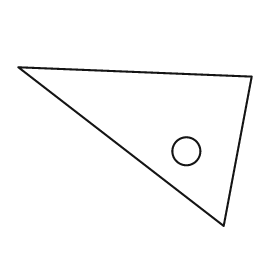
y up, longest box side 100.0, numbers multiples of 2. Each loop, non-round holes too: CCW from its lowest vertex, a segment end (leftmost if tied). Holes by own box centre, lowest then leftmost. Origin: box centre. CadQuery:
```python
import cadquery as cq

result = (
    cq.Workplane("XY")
    .moveTo(38.0, -34.0)
    .lineTo(50.0, 30.0)
    .lineTo(-50.0, 34.0)
    .close()
    .moveTo(22.0, -2.0)
    .circle(6.0)
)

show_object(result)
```